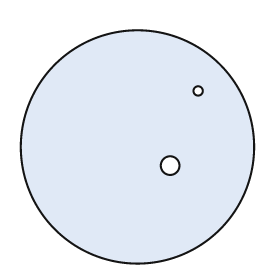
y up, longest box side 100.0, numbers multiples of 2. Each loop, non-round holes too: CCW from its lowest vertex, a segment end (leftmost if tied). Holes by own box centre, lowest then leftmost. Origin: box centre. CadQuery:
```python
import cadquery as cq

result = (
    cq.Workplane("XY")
    .moveTo(0.0, 0.0)
    .circle(50.0)
    .moveTo(14.0, -8.0)
    .circle(4.0)
    .moveTo(26.0, 24.0)
    .circle(2.0)
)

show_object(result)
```